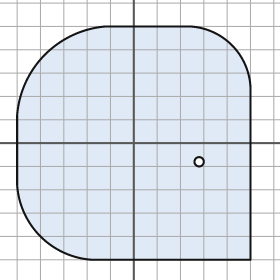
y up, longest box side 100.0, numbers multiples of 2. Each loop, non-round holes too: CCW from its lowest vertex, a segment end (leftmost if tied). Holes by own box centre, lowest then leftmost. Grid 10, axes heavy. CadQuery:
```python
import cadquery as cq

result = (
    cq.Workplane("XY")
    .moveTo(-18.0, -50.0)
    .lineTo(50.0, -50.0)
    .lineTo(50.0, 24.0)
    .threePointArc((42.0, 42.0), (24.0, 50.0))
    .lineTo(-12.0, 50.0)
    .threePointArc((-38.0, 38.0), (-50.0, 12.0))
    .lineTo(-50.0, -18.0)
    .threePointArc((-40.0, -40.0), (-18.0, -50.0))
    .close()
    .moveTo(28.0, -8.0)
    .circle(2.0)
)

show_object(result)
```